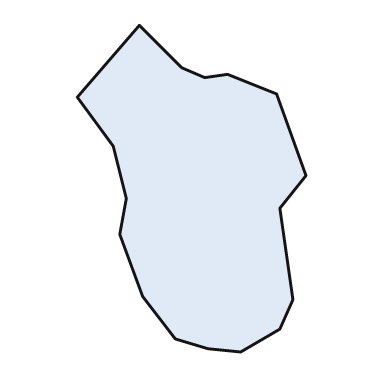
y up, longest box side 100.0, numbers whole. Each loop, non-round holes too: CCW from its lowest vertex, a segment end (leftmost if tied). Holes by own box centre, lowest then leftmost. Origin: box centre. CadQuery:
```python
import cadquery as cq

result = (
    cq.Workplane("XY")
    .moveTo(15.0, -50.0)
    .lineTo(27.0, -43.0)
    .lineTo(31.0, -34.0)
    .lineTo(27.0, -6.0)
    .lineTo(35.0, 4.0)
    .lineTo(26.0, 29.0)
    .lineTo(11.0, 35.0)
    .lineTo(4.0, 34.0)
    .lineTo(-3.0, 37.0)
    .lineTo(-16.0, 50.0)
    .lineTo(-35.0, 28.0)
    .lineTo(-24.0, 13.0)
    .lineTo(-20.0, -3.0)
    .lineTo(-22.0, -14.0)
    .lineTo(-15.0, -33.0)
    .lineTo(-5.0, -46.0)
    .lineTo(5.0, -49.0)
    .close()
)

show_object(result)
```